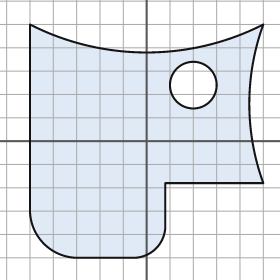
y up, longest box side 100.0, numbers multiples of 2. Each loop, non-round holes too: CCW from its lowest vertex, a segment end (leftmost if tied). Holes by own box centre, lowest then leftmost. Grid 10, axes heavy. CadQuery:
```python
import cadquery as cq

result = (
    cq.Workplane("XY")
    .moveTo(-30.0, -50.0)
    .lineTo(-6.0, -50.0)
    .threePointArc((4.0, -46.0), (8.0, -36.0))
    .lineTo(8.0, -18.0)
    .lineTo(50.0, -18.0)
    .threePointArc((44.0, 16.0), (50.0, 50.0))
    .threePointArc((0.0, 38.0), (-50.0, 50.0))
    .lineTo(-50.0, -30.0)
    .threePointArc((-44.0, -44.0), (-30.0, -50.0))
    .close()
    .moveTo(20.0, 24.0)
    .circle(10.0)
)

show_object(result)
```